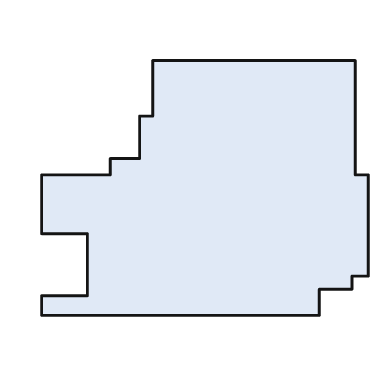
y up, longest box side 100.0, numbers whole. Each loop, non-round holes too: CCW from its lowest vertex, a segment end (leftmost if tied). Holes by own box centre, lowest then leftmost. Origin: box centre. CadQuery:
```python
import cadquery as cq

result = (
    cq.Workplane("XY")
    .moveTo(-50.0, -39.0)
    .lineTo(35.0, -39.0)
    .lineTo(35.0, -31.0)
    .lineTo(45.0, -31.0)
    .lineTo(45.0, -27.0)
    .lineTo(50.0, -27.0)
    .lineTo(50.0, 4.0)
    .lineTo(46.0, 4.0)
    .lineTo(46.0, 39.0)
    .lineTo(-16.0, 39.0)
    .lineTo(-16.0, 22.0)
    .lineTo(-20.0, 22.0)
    .lineTo(-20.0, 9.0)
    .lineTo(-29.0, 9.0)
    .lineTo(-29.0, 4.0)
    .lineTo(-50.0, 4.0)
    .lineTo(-50.0, -14.0)
    .lineTo(-36.0, -14.0)
    .lineTo(-36.0, -33.0)
    .lineTo(-50.0, -33.0)
    .close()
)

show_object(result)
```